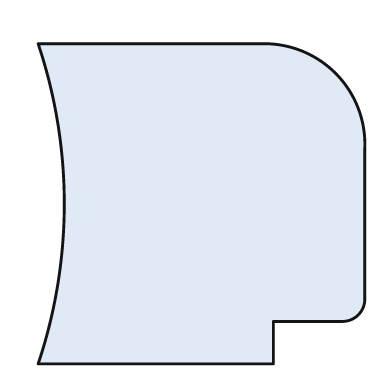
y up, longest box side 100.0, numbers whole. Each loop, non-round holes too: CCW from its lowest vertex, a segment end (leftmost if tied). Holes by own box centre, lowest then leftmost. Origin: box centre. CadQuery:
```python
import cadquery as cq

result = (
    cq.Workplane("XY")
    .moveTo(-50.0, -49.0)
    .lineTo(22.0, -49.0)
    .lineTo(22.0, -36.0)
    .lineTo(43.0, -36.0)
    .threePointArc((48.0, -34.0), (50.0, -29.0))
    .lineTo(50.0, 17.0)
    .threePointArc((41.0, 40.0), (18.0, 49.0))
    .lineTo(-50.0, 49.0)
    .threePointArc((-42.0, 0.0), (-50.0, -49.0))
    .close()
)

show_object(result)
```